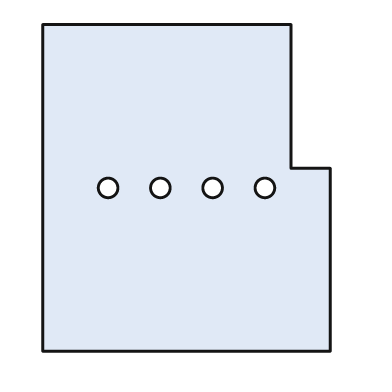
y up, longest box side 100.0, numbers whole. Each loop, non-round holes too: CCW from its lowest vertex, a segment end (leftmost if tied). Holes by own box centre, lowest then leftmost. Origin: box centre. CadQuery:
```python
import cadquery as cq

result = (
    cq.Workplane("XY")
    .moveTo(-44.0, -50.0)
    .lineTo(44.0, -50.0)
    .lineTo(44.0, 6.0)
    .lineTo(32.0, 6.0)
    .lineTo(32.0, 50.0)
    .lineTo(-44.0, 50.0)
    .close()
    .moveTo(-24.0, 0.0)
    .circle(3.0)
    .moveTo(-8.0, 0.0)
    .circle(3.0)
    .moveTo(8.0, 0.0)
    .circle(3.0)
    .moveTo(24.0, 0.0)
    .circle(3.0)
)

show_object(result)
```